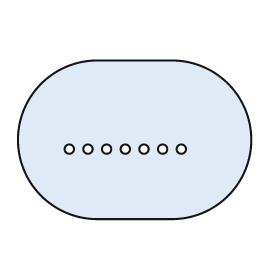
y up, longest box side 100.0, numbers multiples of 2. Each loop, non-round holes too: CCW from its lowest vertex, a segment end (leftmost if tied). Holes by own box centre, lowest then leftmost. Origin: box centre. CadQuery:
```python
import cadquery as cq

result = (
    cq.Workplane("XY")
    .moveTo(-16.0, -34.0)
    .lineTo(16.0, -34.0)
    .threePointArc((50.0, 0.0), (16.0, 34.0))
    .lineTo(-16.0, 34.0)
    .threePointArc((-50.0, 0.0), (-16.0, -34.0))
    .close()
    .moveTo(-28.0, -4.0)
    .circle(2.0)
    .moveTo(-20.0, -4.0)
    .circle(2.0)
    .moveTo(-12.0, -4.0)
    .circle(2.0)
    .moveTo(-4.0, -4.0)
    .circle(2.0)
    .moveTo(4.0, -4.0)
    .circle(2.0)
    .moveTo(12.0, -4.0)
    .circle(2.0)
    .moveTo(20.0, -4.0)
    .circle(2.0)
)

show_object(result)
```